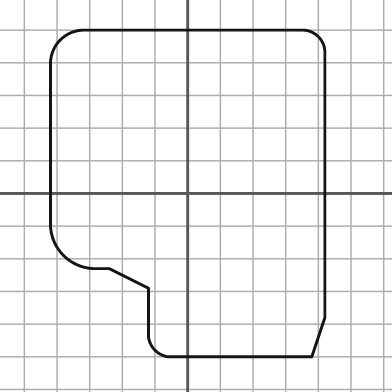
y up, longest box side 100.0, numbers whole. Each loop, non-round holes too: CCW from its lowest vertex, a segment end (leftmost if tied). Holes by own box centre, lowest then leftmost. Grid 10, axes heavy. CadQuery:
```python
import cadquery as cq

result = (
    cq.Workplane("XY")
    .moveTo(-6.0, -50.0)
    .lineTo(38.0, -50.0)
    .lineTo(42.0, -38.0)
    .lineTo(42.0, 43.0)
    .threePointArc((40.0, 48.0), (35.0, 50.0))
    .lineTo(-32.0, 50.0)
    .threePointArc((-39.0, 47.0), (-42.0, 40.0))
    .lineTo(-42.0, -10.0)
    .threePointArc((-38.0, -19.0), (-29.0, -23.0))
    .lineTo(-24.0, -23.0)
    .lineTo(-12.0, -29.0)
    .lineTo(-12.0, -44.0)
    .threePointArc((-10.0, -48.0), (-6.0, -50.0))
    .close()
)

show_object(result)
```